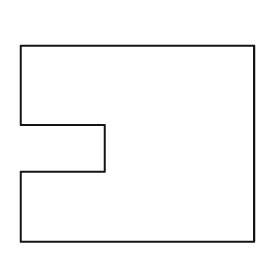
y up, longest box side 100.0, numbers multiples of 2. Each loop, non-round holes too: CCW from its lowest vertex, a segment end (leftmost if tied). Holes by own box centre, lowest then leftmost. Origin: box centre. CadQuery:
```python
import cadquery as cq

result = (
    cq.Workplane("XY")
    .moveTo(-50.0, -42.0)
    .lineTo(50.0, -42.0)
    .lineTo(50.0, 42.0)
    .lineTo(-50.0, 42.0)
    .lineTo(-50.0, 8.0)
    .lineTo(-14.0, 8.0)
    .lineTo(-14.0, -12.0)
    .lineTo(-50.0, -12.0)
    .close()
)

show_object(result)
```